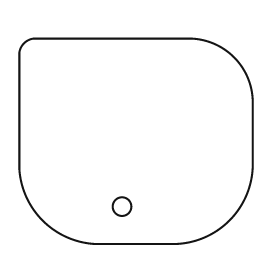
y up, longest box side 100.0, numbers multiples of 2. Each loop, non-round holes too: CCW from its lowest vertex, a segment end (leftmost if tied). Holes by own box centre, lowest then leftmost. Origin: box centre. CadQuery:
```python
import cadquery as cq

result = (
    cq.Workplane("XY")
    .moveTo(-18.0, -44.0)
    .lineTo(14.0, -44.0)
    .threePointArc((40.0, -34.0), (50.0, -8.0))
    .lineTo(50.0, 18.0)
    .threePointArc((42.0, 36.0), (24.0, 44.0))
    .lineTo(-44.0, 44.0)
    .threePointArc((-48.0, 42.0), (-50.0, 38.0))
    .lineTo(-50.0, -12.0)
    .threePointArc((-40.0, -34.0), (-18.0, -44.0))
    .close()
    .moveTo(-6.0, -28.0)
    .circle(4.0)
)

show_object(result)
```